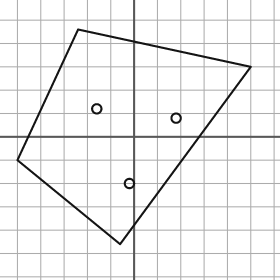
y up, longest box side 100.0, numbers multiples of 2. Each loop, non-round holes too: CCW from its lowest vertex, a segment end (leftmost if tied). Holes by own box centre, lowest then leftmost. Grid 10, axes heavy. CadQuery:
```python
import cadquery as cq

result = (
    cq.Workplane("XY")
    .moveTo(-6.0, -46.0)
    .lineTo(50.0, 30.0)
    .lineTo(-24.0, 46.0)
    .lineTo(-50.0, -10.0)
    .close()
    .moveTo(-2.0, -20.0)
    .circle(2.0)
    .moveTo(18.0, 8.0)
    .circle(2.0)
    .moveTo(-16.0, 12.0)
    .circle(2.0)
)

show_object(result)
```